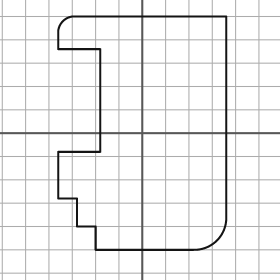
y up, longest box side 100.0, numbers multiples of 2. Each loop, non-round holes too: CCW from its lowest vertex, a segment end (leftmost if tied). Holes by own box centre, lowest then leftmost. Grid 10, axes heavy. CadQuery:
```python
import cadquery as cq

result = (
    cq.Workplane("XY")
    .moveTo(-20.0, -50.0)
    .lineTo(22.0, -50.0)
    .threePointArc((32.0, -46.0), (36.0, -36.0))
    .lineTo(36.0, 50.0)
    .lineTo(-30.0, 50.0)
    .threePointArc((-34.0, 48.0), (-36.0, 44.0))
    .lineTo(-36.0, 36.0)
    .lineTo(-18.0, 36.0)
    .lineTo(-18.0, -8.0)
    .lineTo(-36.0, -8.0)
    .lineTo(-36.0, -28.0)
    .lineTo(-28.0, -28.0)
    .lineTo(-28.0, -40.0)
    .lineTo(-20.0, -40.0)
    .close()
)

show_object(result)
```